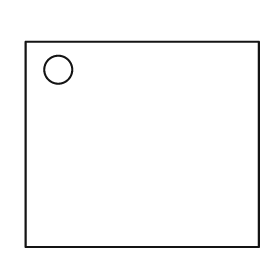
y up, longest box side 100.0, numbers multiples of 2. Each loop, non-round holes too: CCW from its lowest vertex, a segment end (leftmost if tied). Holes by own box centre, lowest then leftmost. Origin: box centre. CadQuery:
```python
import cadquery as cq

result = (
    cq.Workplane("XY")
    .moveTo(-50.0, -44.0)
    .lineTo(50.0, -44.0)
    .lineTo(50.0, 44.0)
    .lineTo(-50.0, 44.0)
    .close()
    .moveTo(-36.0, 32.0)
    .circle(6.0)
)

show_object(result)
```